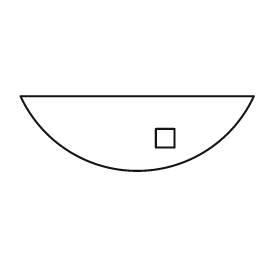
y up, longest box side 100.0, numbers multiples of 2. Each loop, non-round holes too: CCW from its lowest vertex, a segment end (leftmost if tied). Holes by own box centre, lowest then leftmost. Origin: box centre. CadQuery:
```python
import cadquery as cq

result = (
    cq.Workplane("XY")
    .moveTo(-50.0, 16.0)
    .threePointArc((0.0, -16.0), (50.0, 16.0))
    .close()
    .moveTo(8.0, -6.0)
    .lineTo(16.0, -6.0)
    .lineTo(16.0, 2.0)
    .lineTo(8.0, 2.0)
    .close()
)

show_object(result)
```